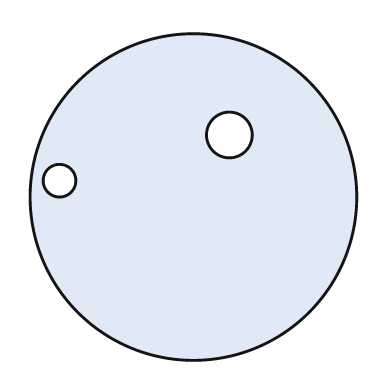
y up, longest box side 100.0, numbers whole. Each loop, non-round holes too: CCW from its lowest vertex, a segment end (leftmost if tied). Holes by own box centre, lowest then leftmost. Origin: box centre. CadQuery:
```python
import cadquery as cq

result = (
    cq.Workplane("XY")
    .moveTo(0.0, 0.0)
    .circle(50.0)
    .moveTo(-41.0, 5.0)
    .circle(5.0)
    .moveTo(11.0, 19.0)
    .circle(7.0)
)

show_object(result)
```